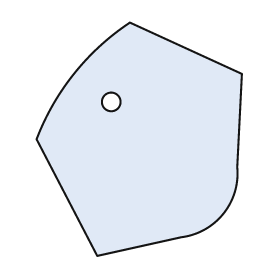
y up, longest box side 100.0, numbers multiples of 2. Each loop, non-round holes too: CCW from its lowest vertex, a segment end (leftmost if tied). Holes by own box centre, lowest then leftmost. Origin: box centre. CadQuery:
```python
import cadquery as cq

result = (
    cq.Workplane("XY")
    .moveTo(-18.0, -50.0)
    .lineTo(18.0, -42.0)
    .threePointArc((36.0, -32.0), (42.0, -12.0))
    .lineTo(44.0, 28.0)
    .lineTo(-4.0, 50.0)
    .threePointArc((-28.0, 28.0), (-44.0, 0.0))
    .close()
    .moveTo(-12.0, 16.0)
    .circle(4.0)
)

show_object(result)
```